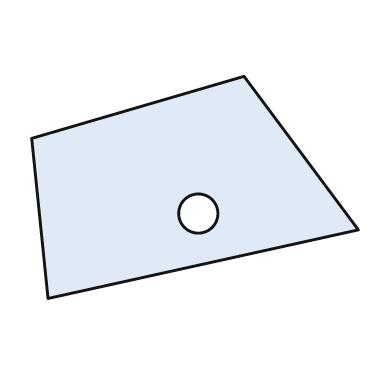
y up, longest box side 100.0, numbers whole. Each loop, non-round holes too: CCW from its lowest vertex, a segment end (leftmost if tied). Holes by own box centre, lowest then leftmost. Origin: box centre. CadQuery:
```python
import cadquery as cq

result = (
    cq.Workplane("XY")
    .moveTo(-45.0, -34.0)
    .lineTo(50.0, -13.0)
    .lineTo(15.0, 34.0)
    .lineTo(-50.0, 15.0)
    .close()
    .moveTo(1.0, -8.0)
    .circle(6.0)
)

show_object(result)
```